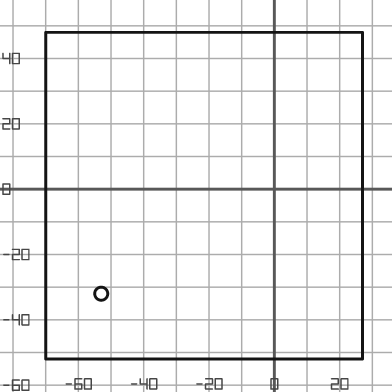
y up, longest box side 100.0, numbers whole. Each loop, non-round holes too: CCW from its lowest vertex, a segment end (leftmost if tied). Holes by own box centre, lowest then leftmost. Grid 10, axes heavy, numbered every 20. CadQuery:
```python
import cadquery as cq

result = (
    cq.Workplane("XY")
    .moveTo(-70.0, -52.0)
    .lineTo(27.0, -52.0)
    .lineTo(27.0, 48.0)
    .lineTo(-70.0, 48.0)
    .close()
    .moveTo(-53.0, -32.0)
    .circle(2.0)
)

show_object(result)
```